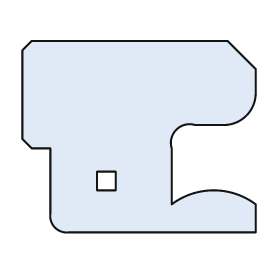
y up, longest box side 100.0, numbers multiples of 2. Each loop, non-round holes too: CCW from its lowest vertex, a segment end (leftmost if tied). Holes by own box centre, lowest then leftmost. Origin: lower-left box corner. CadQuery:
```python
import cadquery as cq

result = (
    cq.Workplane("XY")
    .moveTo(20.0, 0.0)
    .lineTo(100.0, 0.0)
    .lineTo(100.0, 12.0)
    .threePointArc((82.0, 18.0), (64.0, 12.0))
    .lineTo(64.0, 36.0)
    .threePointArc((66.0, 44.0), (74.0, 46.0))
    .lineTo(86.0, 46.0)
    .threePointArc((96.0, 50.0), (100.0, 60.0))
    .lineTo(100.0, 70.0)
    .lineTo(88.0, 82.0)
    .lineTo(4.0, 82.0)
    .lineTo(0.0, 78.0)
    .lineTo(0.0, 40.0)
    .lineTo(4.0, 36.0)
    .lineTo(12.0, 36.0)
    .lineTo(12.0, 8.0)
    .threePointArc((14.0, 2.0), (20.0, 0.0))
    .close()
    .moveTo(32.0, 18.0)
    .lineTo(40.0, 18.0)
    .lineTo(40.0, 26.0)
    .lineTo(32.0, 26.0)
    .close()
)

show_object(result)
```